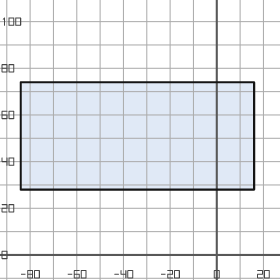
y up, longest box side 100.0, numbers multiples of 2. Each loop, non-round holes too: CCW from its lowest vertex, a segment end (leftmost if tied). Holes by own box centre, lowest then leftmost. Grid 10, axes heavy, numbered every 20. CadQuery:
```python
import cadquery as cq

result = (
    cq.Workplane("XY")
    .moveTo(-84.0, 28.0)
    .lineTo(16.0, 28.0)
    .lineTo(16.0, 74.0)
    .lineTo(-84.0, 74.0)
    .close()
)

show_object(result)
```